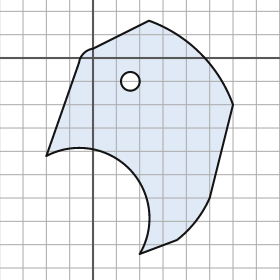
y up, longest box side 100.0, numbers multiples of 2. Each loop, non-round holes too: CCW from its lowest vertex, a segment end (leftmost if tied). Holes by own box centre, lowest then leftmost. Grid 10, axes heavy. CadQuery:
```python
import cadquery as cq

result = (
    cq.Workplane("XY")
    .moveTo(20.0, -84.0)
    .lineTo(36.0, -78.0)
    .threePointArc((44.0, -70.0), (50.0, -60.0))
    .lineTo(60.0, -20.0)
    .threePointArc((46.0, 2.0), (24.0, 16.0))
    .lineTo(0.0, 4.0)
    .threePointArc((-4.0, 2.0), (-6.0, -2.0))
    .lineTo(-20.0, -42.0)
    .threePointArc((16.0, -48.0), (20.0, -84.0))
    .close()
    .moveTo(16.0, -10.0)
    .circle(4.0)
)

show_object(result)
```